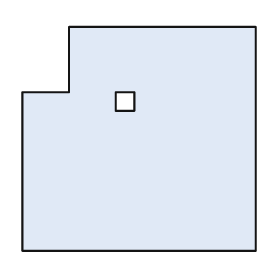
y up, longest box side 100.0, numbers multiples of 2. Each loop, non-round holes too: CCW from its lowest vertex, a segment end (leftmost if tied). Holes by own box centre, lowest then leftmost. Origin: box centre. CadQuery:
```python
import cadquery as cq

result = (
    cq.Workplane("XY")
    .moveTo(-50.0, -48.0)
    .lineTo(50.0, -48.0)
    .lineTo(50.0, 48.0)
    .lineTo(-30.0, 48.0)
    .lineTo(-30.0, 20.0)
    .lineTo(-50.0, 20.0)
    .close()
    .moveTo(-10.0, 12.0)
    .lineTo(-2.0, 12.0)
    .lineTo(-2.0, 20.0)
    .lineTo(-10.0, 20.0)
    .close()
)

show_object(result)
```